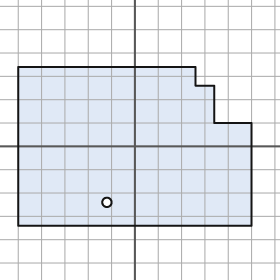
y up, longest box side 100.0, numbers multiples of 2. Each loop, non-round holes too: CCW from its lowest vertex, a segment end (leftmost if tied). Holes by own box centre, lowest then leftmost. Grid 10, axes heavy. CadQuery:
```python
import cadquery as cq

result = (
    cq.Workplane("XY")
    .moveTo(-50.0, -34.0)
    .lineTo(50.0, -34.0)
    .lineTo(50.0, 10.0)
    .lineTo(34.0, 10.0)
    .lineTo(34.0, 26.0)
    .lineTo(26.0, 26.0)
    .lineTo(26.0, 34.0)
    .lineTo(-50.0, 34.0)
    .close()
    .moveTo(-12.0, -24.0)
    .circle(2.0)
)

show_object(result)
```